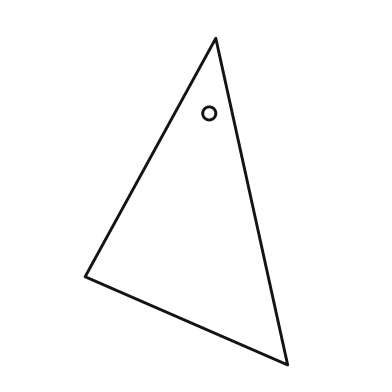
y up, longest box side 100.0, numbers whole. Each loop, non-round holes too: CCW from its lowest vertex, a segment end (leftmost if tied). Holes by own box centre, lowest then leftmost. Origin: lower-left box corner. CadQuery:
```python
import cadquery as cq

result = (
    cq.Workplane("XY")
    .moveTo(62.0, 0.0)
    .lineTo(40.0, 100.0)
    .lineTo(0.0, 27.0)
    .close()
    .moveTo(38.0, 77.0)
    .circle(2.0)
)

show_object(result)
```